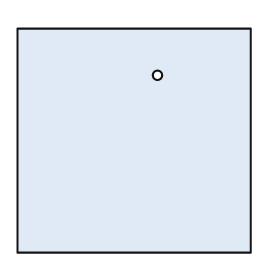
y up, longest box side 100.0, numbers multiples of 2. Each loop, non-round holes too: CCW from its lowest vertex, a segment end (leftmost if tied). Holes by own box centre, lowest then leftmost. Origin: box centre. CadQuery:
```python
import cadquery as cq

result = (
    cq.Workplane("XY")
    .moveTo(-50.0, -48.0)
    .lineTo(50.0, -48.0)
    .lineTo(50.0, 48.0)
    .lineTo(-50.0, 48.0)
    .close()
    .moveTo(10.0, 28.0)
    .circle(2.0)
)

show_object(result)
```